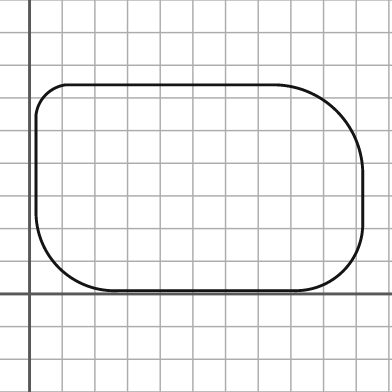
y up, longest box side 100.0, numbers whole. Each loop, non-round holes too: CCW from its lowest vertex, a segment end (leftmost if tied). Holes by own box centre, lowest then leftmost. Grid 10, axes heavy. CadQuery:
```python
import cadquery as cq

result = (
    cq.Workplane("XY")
    .moveTo(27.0, 1.0)
    .lineTo(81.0, 1.0)
    .threePointArc((96.0, 7.0), (102.0, 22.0))
    .lineTo(102.0, 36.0)
    .threePointArc((94.0, 56.0), (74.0, 64.0))
    .lineTo(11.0, 64.0)
    .threePointArc((5.0, 61.0), (2.0, 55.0))
    .lineTo(2.0, 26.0)
    .threePointArc((9.0, 8.0), (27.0, 1.0))
    .close()
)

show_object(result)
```